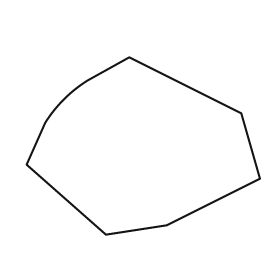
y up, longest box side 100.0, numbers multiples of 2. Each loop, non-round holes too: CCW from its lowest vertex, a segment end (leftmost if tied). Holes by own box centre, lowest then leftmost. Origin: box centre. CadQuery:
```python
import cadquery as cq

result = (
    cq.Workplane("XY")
    .moveTo(-16.0, -38.0)
    .lineTo(10.0, -34.0)
    .lineTo(50.0, -14.0)
    .lineTo(42.0, 14.0)
    .lineTo(-6.0, 38.0)
    .lineTo(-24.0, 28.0)
    .threePointArc((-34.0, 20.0), (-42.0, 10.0))
    .lineTo(-50.0, -8.0)
    .close()
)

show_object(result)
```